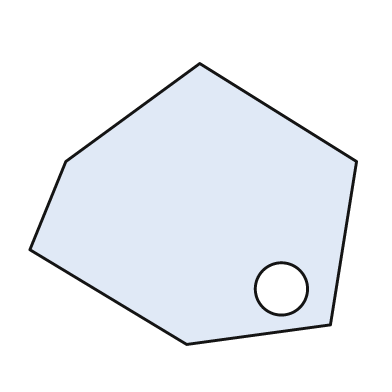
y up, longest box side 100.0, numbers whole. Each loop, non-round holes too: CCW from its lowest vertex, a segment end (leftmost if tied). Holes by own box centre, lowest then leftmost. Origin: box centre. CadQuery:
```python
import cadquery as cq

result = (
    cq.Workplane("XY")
    .moveTo(-2.0, -43.0)
    .lineTo(42.0, -37.0)
    .lineTo(50.0, 13.0)
    .lineTo(2.0, 43.0)
    .lineTo(-39.0, 13.0)
    .lineTo(-50.0, -14.0)
    .close()
    .moveTo(27.0, -26.0)
    .circle(8.0)
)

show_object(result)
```